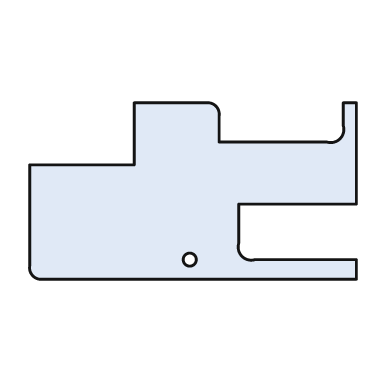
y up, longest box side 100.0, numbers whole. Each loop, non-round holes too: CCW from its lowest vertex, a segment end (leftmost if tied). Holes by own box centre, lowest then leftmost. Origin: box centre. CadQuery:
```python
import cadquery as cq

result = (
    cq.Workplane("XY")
    .moveTo(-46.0, -27.0)
    .lineTo(50.0, -27.0)
    .lineTo(50.0, -21.0)
    .lineTo(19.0, -21.0)
    .threePointArc((15.0, -20.0), (14.0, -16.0))
    .lineTo(14.0, -4.0)
    .lineTo(50.0, -4.0)
    .lineTo(50.0, 27.0)
    .lineTo(46.0, 27.0)
    .lineTo(46.0, 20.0)
    .threePointArc((45.0, 16.0), (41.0, 15.0))
    .lineTo(8.0, 15.0)
    .lineTo(8.0, 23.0)
    .threePointArc((7.0, 26.0), (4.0, 27.0))
    .lineTo(-18.0, 27.0)
    .lineTo(-18.0, 8.0)
    .lineTo(-50.0, 8.0)
    .lineTo(-50.0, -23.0)
    .threePointArc((-49.0, -26.0), (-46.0, -27.0))
    .close()
    .moveTo(-1.0, -21.0)
    .circle(2.0)
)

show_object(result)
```